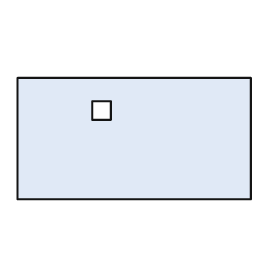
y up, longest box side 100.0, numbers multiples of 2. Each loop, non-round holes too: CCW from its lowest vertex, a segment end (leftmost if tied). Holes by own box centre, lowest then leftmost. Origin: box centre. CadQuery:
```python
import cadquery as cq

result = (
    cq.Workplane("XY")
    .moveTo(-50.0, -26.0)
    .lineTo(50.0, -26.0)
    .lineTo(50.0, 26.0)
    .lineTo(-50.0, 26.0)
    .close()
    .moveTo(-18.0, 8.0)
    .lineTo(-10.0, 8.0)
    .lineTo(-10.0, 16.0)
    .lineTo(-18.0, 16.0)
    .close()
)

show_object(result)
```